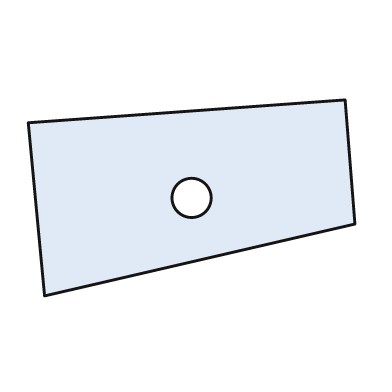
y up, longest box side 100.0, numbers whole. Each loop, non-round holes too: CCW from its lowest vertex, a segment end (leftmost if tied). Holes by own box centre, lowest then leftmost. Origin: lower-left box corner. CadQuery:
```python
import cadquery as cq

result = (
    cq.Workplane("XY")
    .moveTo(5.0, 0.0)
    .lineTo(100.0, 22.0)
    .lineTo(97.0, 60.0)
    .lineTo(0.0, 53.0)
    .close()
    .moveTo(50.0, 30.0)
    .circle(6.0)
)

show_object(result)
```